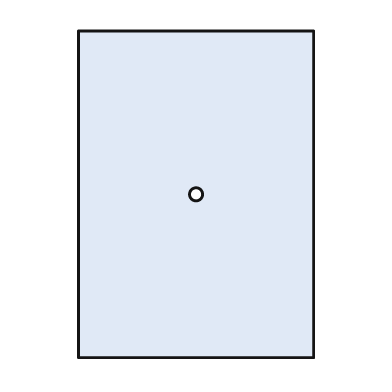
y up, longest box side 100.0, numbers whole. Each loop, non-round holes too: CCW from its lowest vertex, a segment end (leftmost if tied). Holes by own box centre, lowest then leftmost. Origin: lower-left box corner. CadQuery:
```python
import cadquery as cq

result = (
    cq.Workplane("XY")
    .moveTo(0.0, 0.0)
    .lineTo(72.0, 0.0)
    .lineTo(72.0, 100.0)
    .lineTo(0.0, 100.0)
    .close()
    .moveTo(36.0, 50.0)
    .circle(2.0)
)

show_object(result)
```